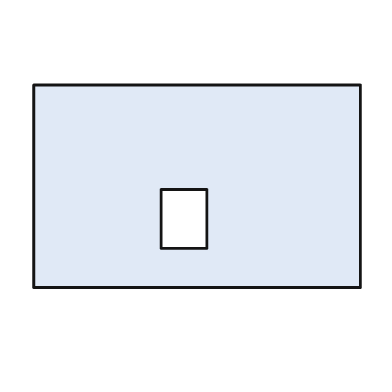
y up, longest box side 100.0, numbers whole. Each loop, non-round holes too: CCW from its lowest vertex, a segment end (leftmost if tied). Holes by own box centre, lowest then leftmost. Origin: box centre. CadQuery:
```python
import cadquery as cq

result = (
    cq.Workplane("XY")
    .moveTo(-50.0, -31.0)
    .lineTo(50.0, -31.0)
    .lineTo(50.0, 31.0)
    .lineTo(-50.0, 31.0)
    .close()
    .moveTo(-11.0, -19.0)
    .lineTo(3.0, -19.0)
    .lineTo(3.0, -1.0)
    .lineTo(-11.0, -1.0)
    .close()
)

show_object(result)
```